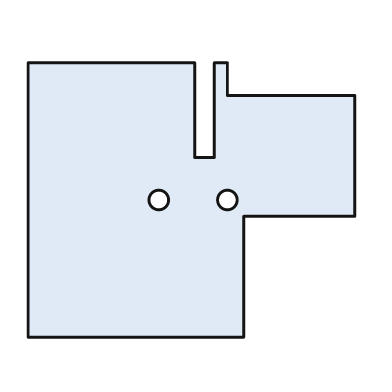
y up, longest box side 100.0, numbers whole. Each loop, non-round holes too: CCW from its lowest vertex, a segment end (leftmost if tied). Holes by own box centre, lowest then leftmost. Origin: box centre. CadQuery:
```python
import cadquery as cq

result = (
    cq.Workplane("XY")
    .moveTo(-50.0, -42.0)
    .lineTo(16.0, -42.0)
    .lineTo(16.0, -5.0)
    .lineTo(50.0, -5.0)
    .lineTo(50.0, 32.0)
    .lineTo(11.0, 32.0)
    .lineTo(11.0, 42.0)
    .lineTo(7.0, 42.0)
    .lineTo(7.0, 13.0)
    .lineTo(1.0, 13.0)
    .lineTo(1.0, 42.0)
    .lineTo(-50.0, 42.0)
    .close()
    .moveTo(-10.0, 0.0)
    .circle(3.0)
    .moveTo(11.0, 0.0)
    .circle(3.0)
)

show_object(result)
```